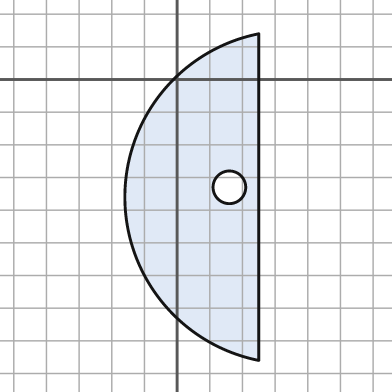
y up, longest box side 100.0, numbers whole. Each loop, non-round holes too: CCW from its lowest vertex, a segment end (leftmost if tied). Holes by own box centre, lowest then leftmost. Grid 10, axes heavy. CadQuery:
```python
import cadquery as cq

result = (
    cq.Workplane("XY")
    .moveTo(25.0, -86.0)
    .lineTo(25.0, 14.0)
    .threePointArc((-16.0, -36.0), (25.0, -86.0))
    .close()
    .moveTo(16.0, -33.0)
    .circle(5.0)
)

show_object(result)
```